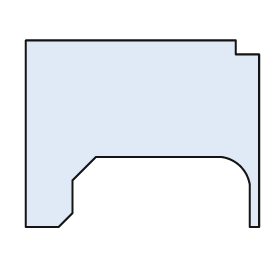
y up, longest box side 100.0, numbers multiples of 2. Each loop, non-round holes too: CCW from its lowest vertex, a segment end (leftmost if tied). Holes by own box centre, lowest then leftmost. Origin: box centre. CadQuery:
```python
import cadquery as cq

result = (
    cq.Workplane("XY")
    .moveTo(-50.0, -40.0)
    .lineTo(-36.0, -40.0)
    .lineTo(-30.0, -34.0)
    .lineTo(-30.0, -20.0)
    .lineTo(-20.0, -10.0)
    .lineTo(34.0, -10.0)
    .threePointArc((42.0, -14.0), (46.0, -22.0))
    .lineTo(46.0, -40.0)
    .lineTo(50.0, -40.0)
    .lineTo(50.0, 34.0)
    .lineTo(40.0, 34.0)
    .lineTo(40.0, 40.0)
    .lineTo(-50.0, 40.0)
    .close()
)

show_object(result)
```